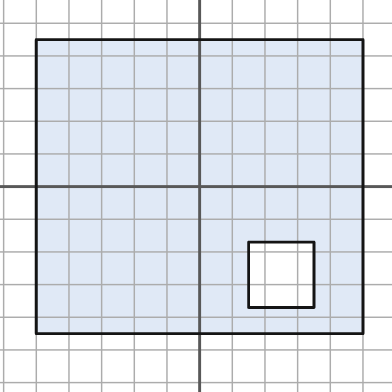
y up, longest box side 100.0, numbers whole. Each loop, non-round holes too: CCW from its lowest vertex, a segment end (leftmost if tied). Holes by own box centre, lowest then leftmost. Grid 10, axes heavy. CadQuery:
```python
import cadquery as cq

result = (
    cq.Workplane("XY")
    .moveTo(-50.0, -45.0)
    .lineTo(50.0, -45.0)
    .lineTo(50.0, 45.0)
    .lineTo(-50.0, 45.0)
    .close()
    .moveTo(15.0, -37.0)
    .lineTo(35.0, -37.0)
    .lineTo(35.0, -17.0)
    .lineTo(15.0, -17.0)
    .close()
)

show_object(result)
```